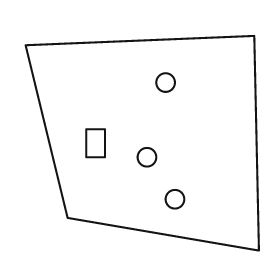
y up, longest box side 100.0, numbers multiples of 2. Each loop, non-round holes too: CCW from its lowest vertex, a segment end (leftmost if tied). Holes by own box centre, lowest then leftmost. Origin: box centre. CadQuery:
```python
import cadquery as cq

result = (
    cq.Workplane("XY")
    .moveTo(50.0, -46.0)
    .lineTo(48.0, 46.0)
    .lineTo(-50.0, 42.0)
    .lineTo(-32.0, -32.0)
    .close()
    .moveTo(14.0, -24.0)
    .circle(4.0)
    .moveTo(2.0, -6.0)
    .circle(4.0)
    .moveTo(-24.0, -6.0)
    .lineTo(-16.0, -6.0)
    .lineTo(-16.0, 6.0)
    .lineTo(-24.0, 6.0)
    .close()
    .moveTo(10.0, 26.0)
    .circle(4.0)
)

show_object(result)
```